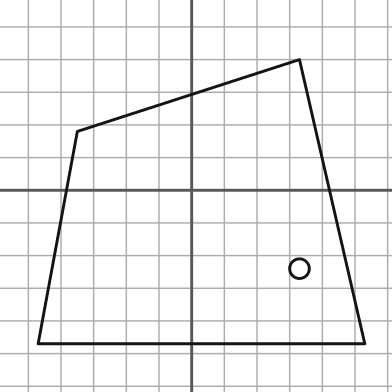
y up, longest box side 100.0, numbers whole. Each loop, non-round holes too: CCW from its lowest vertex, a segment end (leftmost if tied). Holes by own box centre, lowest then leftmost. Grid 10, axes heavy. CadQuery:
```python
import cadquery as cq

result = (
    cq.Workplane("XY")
    .moveTo(-47.0, -47.0)
    .lineTo(53.0, -47.0)
    .lineTo(33.0, 40.0)
    .lineTo(-35.0, 18.0)
    .close()
    .moveTo(33.0, -24.0)
    .circle(3.0)
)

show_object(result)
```